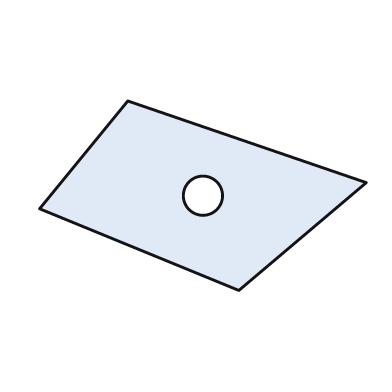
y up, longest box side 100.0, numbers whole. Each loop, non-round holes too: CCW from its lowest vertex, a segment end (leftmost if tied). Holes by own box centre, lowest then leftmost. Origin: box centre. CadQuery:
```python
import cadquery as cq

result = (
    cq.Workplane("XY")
    .moveTo(11.0, -29.0)
    .lineTo(50.0, 4.0)
    .lineTo(-23.0, 29.0)
    .lineTo(-50.0, -4.0)
    .close()
    .moveTo(0.0, 0.0)
    .circle(6.0)
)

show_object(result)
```